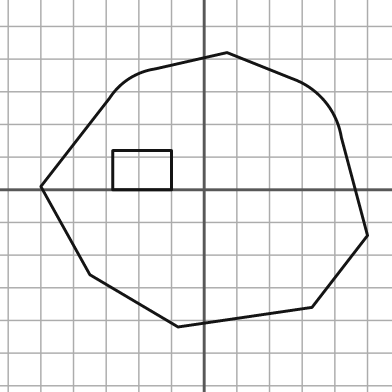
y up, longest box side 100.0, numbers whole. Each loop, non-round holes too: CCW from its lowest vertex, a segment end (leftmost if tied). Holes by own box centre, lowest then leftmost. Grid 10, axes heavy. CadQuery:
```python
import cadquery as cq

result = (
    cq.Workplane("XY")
    .moveTo(-8.0, -42.0)
    .lineTo(33.0, -36.0)
    .lineTo(50.0, -14.0)
    .lineTo(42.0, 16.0)
    .threePointArc((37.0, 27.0), (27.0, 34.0))
    .lineTo(7.0, 42.0)
    .lineTo(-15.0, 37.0)
    .threePointArc((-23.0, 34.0), (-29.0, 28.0))
    .lineTo(-50.0, 1.0)
    .lineTo(-35.0, -26.0)
    .close()
    .moveTo(-28.0, 0.0)
    .lineTo(-10.0, 0.0)
    .lineTo(-10.0, 12.0)
    .lineTo(-28.0, 12.0)
    .close()
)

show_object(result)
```